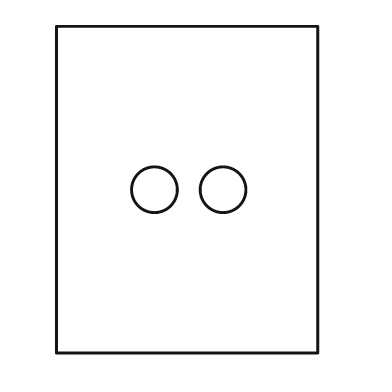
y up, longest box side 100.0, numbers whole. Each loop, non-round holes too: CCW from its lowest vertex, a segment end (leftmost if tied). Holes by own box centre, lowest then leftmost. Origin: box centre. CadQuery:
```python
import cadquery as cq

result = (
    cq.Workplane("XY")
    .moveTo(-40.0, -50.0)
    .lineTo(40.0, -50.0)
    .lineTo(40.0, 50.0)
    .lineTo(-40.0, 50.0)
    .close()
    .moveTo(-10.0, 0.0)
    .circle(7.0)
    .moveTo(11.0, 0.0)
    .circle(7.0)
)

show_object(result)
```